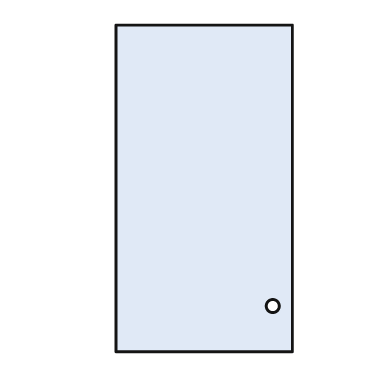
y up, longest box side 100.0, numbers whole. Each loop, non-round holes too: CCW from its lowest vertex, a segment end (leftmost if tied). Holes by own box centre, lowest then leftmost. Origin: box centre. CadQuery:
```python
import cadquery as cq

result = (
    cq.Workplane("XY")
    .moveTo(-27.0, -50.0)
    .lineTo(27.0, -50.0)
    .lineTo(27.0, 50.0)
    .lineTo(-27.0, 50.0)
    .close()
    .moveTo(21.0, -36.0)
    .circle(2.0)
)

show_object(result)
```